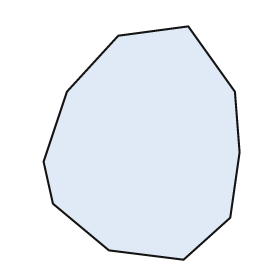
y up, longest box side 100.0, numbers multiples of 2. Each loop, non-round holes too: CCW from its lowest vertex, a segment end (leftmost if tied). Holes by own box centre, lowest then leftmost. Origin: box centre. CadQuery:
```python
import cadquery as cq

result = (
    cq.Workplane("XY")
    .moveTo(18.0, -50.0)
    .lineTo(38.0, -32.0)
    .lineTo(42.0, -4.0)
    .lineTo(40.0, 22.0)
    .lineTo(20.0, 50.0)
    .lineTo(-10.0, 46.0)
    .lineTo(-32.0, 22.0)
    .lineTo(-42.0, -8.0)
    .lineTo(-38.0, -26.0)
    .lineTo(-14.0, -46.0)
    .close()
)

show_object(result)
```